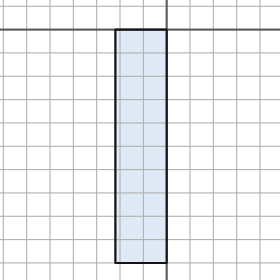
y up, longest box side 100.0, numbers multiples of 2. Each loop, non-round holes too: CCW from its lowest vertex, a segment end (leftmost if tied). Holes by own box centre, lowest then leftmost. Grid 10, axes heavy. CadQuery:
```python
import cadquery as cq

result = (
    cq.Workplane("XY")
    .moveTo(-22.0, -100.0)
    .lineTo(0.0, -100.0)
    .lineTo(0.0, 0.0)
    .lineTo(-22.0, 0.0)
    .close()
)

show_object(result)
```